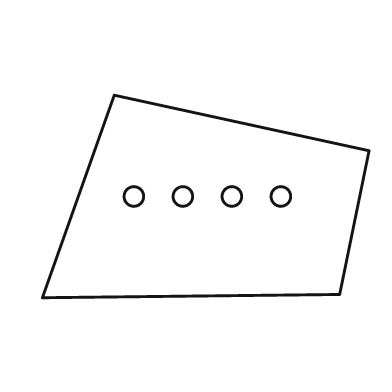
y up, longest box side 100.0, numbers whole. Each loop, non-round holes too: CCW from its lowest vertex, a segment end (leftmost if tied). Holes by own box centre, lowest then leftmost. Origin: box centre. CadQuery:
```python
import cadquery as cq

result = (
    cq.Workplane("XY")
    .moveTo(-50.0, -31.0)
    .lineTo(41.0, -30.0)
    .lineTo(50.0, 14.0)
    .lineTo(-28.0, 31.0)
    .close()
    .moveTo(-22.0, 0.0)
    .circle(3.0)
    .moveTo(-7.0, 0.0)
    .circle(3.0)
    .moveTo(8.0, 0.0)
    .circle(3.0)
    .moveTo(23.0, 0.0)
    .circle(3.0)
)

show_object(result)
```